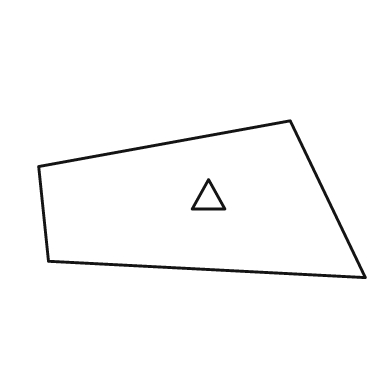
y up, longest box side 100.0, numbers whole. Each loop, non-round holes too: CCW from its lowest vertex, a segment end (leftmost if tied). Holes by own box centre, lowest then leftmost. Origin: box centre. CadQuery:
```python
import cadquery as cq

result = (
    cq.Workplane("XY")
    .moveTo(50.0, -24.0)
    .lineTo(27.0, 24.0)
    .lineTo(-50.0, 10.0)
    .lineTo(-47.0, -19.0)
    .close()
    .moveTo(-3.0, -3.0)
    .lineTo(7.0, -3.0)
    .lineTo(2.0, 6.0)
    .close()
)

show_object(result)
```